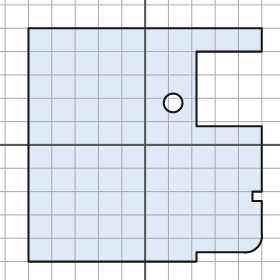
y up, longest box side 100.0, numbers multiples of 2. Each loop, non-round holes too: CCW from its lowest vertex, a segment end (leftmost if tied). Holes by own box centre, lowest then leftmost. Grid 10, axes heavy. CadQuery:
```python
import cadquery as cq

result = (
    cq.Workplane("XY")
    .moveTo(-50.0, -50.0)
    .lineTo(22.0, -50.0)
    .lineTo(22.0, -46.0)
    .lineTo(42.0, -46.0)
    .threePointArc((48.0, -44.0), (50.0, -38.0))
    .lineTo(50.0, -24.0)
    .lineTo(46.0, -24.0)
    .lineTo(46.0, -20.0)
    .lineTo(50.0, -20.0)
    .lineTo(50.0, 8.0)
    .lineTo(22.0, 8.0)
    .lineTo(22.0, 40.0)
    .lineTo(50.0, 40.0)
    .lineTo(50.0, 50.0)
    .lineTo(-50.0, 50.0)
    .close()
    .moveTo(12.0, 18.0)
    .circle(4.0)
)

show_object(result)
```